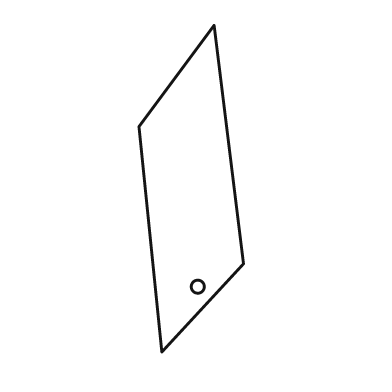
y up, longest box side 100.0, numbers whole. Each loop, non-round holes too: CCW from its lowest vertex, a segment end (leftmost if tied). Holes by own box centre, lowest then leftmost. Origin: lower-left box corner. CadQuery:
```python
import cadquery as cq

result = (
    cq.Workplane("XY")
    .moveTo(7.0, 0.0)
    .lineTo(32.0, 27.0)
    .lineTo(23.0, 100.0)
    .lineTo(0.0, 69.0)
    .close()
    .moveTo(18.0, 20.0)
    .circle(2.0)
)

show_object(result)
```